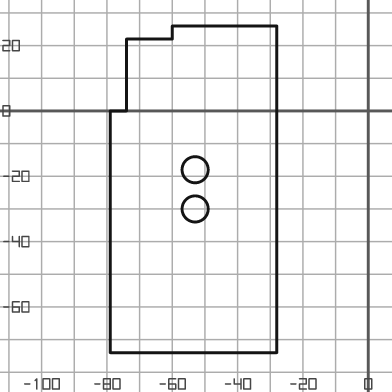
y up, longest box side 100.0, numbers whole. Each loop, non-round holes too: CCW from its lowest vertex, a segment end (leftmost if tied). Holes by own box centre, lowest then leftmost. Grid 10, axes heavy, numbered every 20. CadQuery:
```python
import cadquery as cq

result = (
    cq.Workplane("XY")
    .moveTo(-79.0, -74.0)
    .lineTo(-28.0, -74.0)
    .lineTo(-28.0, 26.0)
    .lineTo(-60.0, 26.0)
    .lineTo(-60.0, 22.0)
    .lineTo(-74.0, 22.0)
    .lineTo(-74.0, 0.0)
    .lineTo(-79.0, 0.0)
    .close()
    .moveTo(-53.0, -30.0)
    .circle(4.0)
    .moveTo(-53.0, -18.0)
    .circle(4.0)
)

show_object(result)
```